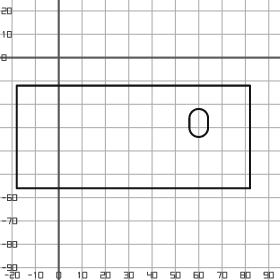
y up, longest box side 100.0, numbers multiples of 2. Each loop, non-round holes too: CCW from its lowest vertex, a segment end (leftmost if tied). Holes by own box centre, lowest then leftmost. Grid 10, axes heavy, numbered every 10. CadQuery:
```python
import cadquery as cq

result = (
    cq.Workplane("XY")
    .moveTo(-18.0, -56.0)
    .lineTo(82.0, -56.0)
    .lineTo(82.0, -12.0)
    .lineTo(-18.0, -12.0)
    .close()
    .moveTo(56.0, -30.0)
    .threePointArc((60.0, -34.0), (64.0, -30.0))
    .lineTo(64.0, -26.0)
    .threePointArc((60.0, -22.0), (56.0, -26.0))
    .close()
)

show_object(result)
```